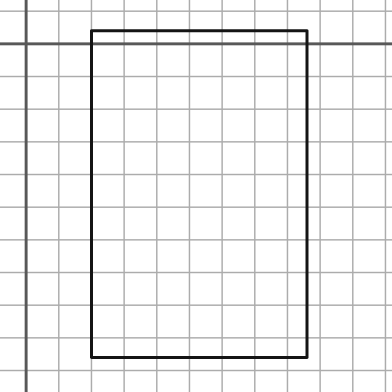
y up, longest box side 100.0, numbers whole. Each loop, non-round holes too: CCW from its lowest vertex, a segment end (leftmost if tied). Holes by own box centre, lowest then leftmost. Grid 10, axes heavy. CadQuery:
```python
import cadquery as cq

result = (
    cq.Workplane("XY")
    .moveTo(20.0, -96.0)
    .lineTo(86.0, -96.0)
    .lineTo(86.0, 4.0)
    .lineTo(20.0, 4.0)
    .close()
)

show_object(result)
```